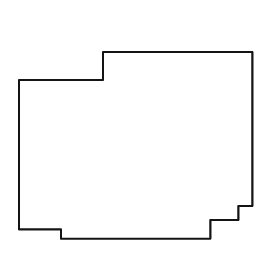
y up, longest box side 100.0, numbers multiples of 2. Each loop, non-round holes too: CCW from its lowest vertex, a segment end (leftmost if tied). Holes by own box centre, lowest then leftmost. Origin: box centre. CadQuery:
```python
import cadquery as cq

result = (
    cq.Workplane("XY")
    .moveTo(-32.0, -40.0)
    .lineTo(32.0, -40.0)
    .lineTo(32.0, -32.0)
    .lineTo(44.0, -32.0)
    .lineTo(44.0, -26.0)
    .lineTo(50.0, -26.0)
    .lineTo(50.0, 40.0)
    .lineTo(-14.0, 40.0)
    .lineTo(-14.0, 28.0)
    .lineTo(-50.0, 28.0)
    .lineTo(-50.0, -36.0)
    .lineTo(-32.0, -36.0)
    .close()
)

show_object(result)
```